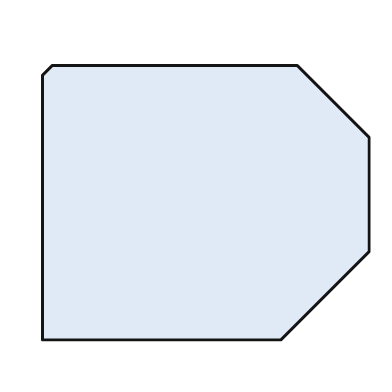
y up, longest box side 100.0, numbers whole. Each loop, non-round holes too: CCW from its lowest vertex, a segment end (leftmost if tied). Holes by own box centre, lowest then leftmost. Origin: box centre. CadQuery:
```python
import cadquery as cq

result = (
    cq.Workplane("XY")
    .moveTo(-50.0, -42.0)
    .lineTo(23.0, -42.0)
    .lineTo(50.0, -15.0)
    .lineTo(50.0, 20.0)
    .lineTo(28.0, 42.0)
    .lineTo(-47.0, 42.0)
    .lineTo(-50.0, 39.0)
    .close()
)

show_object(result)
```